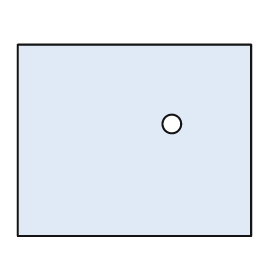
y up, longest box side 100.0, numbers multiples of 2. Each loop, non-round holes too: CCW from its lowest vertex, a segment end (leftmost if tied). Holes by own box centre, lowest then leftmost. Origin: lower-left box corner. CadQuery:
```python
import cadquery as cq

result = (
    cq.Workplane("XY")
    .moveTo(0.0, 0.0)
    .lineTo(100.0, 0.0)
    .lineTo(100.0, 82.0)
    .lineTo(0.0, 82.0)
    .close()
    .moveTo(66.0, 48.0)
    .circle(4.0)
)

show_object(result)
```